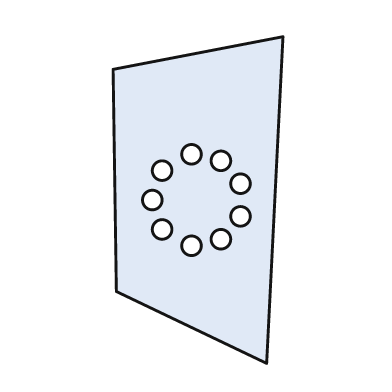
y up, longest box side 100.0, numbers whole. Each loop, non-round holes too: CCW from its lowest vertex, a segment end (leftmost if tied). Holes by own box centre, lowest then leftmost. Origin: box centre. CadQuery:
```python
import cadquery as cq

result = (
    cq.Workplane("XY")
    .moveTo(21.0, -50.0)
    .lineTo(26.0, 50.0)
    .lineTo(-26.0, 40.0)
    .lineTo(-25.0, -28.0)
    .close()
    .moveTo(-2.0, -14.0)
    .circle(3.0)
    .moveTo(7.0, -12.0)
    .circle(3.0)
    .moveTo(-11.0, -9.0)
    .circle(3.0)
    .moveTo(13.0, -5.0)
    .circle(3.0)
    .moveTo(-14.0, 0.0)
    .circle(3.0)
    .moveTo(13.0, 5.0)
    .circle(3.0)
    .moveTo(-11.0, 9.0)
    .circle(3.0)
    .moveTo(7.0, 12.0)
    .circle(3.0)
    .moveTo(-2.0, 14.0)
    .circle(3.0)
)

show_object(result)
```